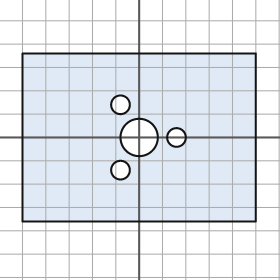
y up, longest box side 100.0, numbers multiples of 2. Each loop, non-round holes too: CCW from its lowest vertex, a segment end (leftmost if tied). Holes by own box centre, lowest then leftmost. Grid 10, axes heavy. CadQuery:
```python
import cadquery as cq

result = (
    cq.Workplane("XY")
    .moveTo(-50.0, -36.0)
    .lineTo(50.0, -36.0)
    .lineTo(50.0, 36.0)
    .lineTo(-50.0, 36.0)
    .close()
    .moveTo(-8.0, -14.0)
    .circle(4.0)
    .moveTo(0.0, 0.0)
    .circle(8.0)
    .moveTo(16.0, 0.0)
    .circle(4.0)
    .moveTo(-8.0, 14.0)
    .circle(4.0)
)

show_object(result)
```